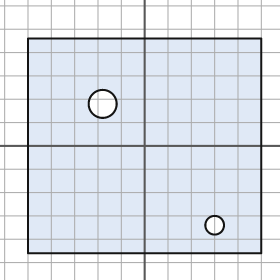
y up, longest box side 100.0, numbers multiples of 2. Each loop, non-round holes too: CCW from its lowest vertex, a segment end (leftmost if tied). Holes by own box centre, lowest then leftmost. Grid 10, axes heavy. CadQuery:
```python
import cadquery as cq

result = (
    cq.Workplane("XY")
    .moveTo(-50.0, -46.0)
    .lineTo(50.0, -46.0)
    .lineTo(50.0, 46.0)
    .lineTo(-50.0, 46.0)
    .close()
    .moveTo(30.0, -34.0)
    .circle(4.0)
    .moveTo(-18.0, 18.0)
    .circle(6.0)
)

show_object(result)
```